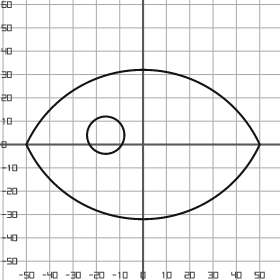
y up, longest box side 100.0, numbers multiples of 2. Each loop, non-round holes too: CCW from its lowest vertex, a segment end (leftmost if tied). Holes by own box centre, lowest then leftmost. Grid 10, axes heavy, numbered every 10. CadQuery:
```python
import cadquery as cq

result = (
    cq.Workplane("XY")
    .moveTo(-50.0, 0.0)
    .threePointArc((0.0, -32.0), (50.0, 0.0))
    .threePointArc((0.0, 32.0), (-50.0, 0.0))
    .close()
    .moveTo(-16.0, 4.0)
    .circle(8.0)
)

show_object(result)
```